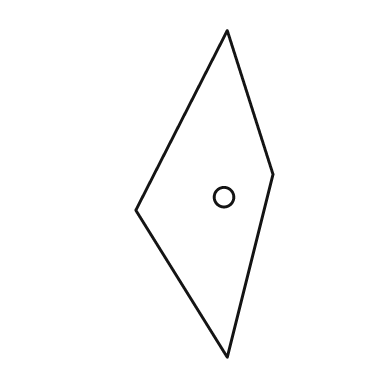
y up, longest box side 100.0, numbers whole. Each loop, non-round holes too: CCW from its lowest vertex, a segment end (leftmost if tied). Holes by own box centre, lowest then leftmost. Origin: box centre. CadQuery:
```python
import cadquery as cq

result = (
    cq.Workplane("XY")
    .moveTo(7.0, -50.0)
    .lineTo(21.0, 6.0)
    .lineTo(7.0, 50.0)
    .lineTo(-21.0, -5.0)
    .close()
    .moveTo(6.0, -1.0)
    .circle(3.0)
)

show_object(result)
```